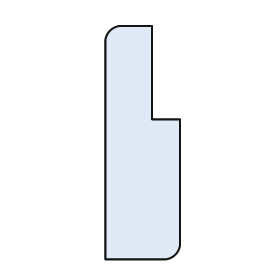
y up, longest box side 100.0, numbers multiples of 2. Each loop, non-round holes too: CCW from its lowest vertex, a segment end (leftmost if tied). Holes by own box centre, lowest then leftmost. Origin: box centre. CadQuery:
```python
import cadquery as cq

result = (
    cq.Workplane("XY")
    .moveTo(-16.0, -50.0)
    .lineTo(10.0, -50.0)
    .threePointArc((14.0, -48.0), (16.0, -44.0))
    .lineTo(16.0, 10.0)
    .lineTo(4.0, 10.0)
    .lineTo(4.0, 50.0)
    .lineTo(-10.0, 50.0)
    .threePointArc((-14.0, 48.0), (-16.0, 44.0))
    .close()
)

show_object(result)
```